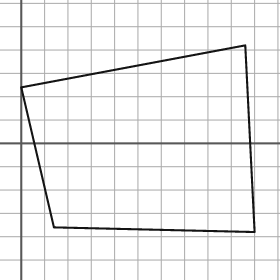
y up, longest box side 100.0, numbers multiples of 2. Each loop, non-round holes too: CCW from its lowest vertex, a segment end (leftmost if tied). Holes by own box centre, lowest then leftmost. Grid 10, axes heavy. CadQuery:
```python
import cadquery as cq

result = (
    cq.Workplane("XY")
    .moveTo(100.0, -38.0)
    .lineTo(96.0, 42.0)
    .lineTo(0.0, 24.0)
    .lineTo(14.0, -36.0)
    .close()
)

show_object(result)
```